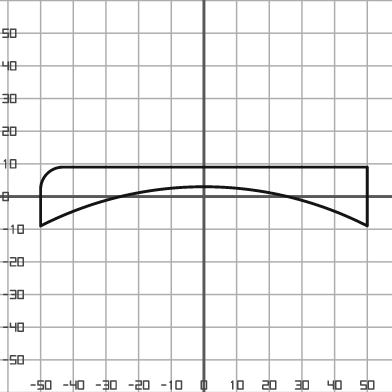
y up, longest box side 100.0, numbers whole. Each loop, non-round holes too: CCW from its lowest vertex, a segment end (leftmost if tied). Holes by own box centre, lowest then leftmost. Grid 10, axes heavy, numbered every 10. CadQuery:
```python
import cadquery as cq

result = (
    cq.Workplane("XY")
    .moveTo(-50.0, -9.0)
    .threePointArc((0.0, 3.0), (50.0, -9.0))
    .lineTo(50.0, 9.0)
    .lineTo(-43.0, 9.0)
    .threePointArc((-48.0, 7.0), (-50.0, 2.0))
    .close()
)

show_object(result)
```